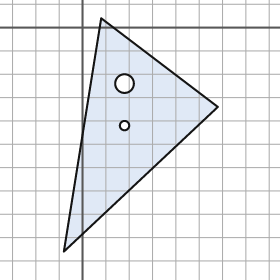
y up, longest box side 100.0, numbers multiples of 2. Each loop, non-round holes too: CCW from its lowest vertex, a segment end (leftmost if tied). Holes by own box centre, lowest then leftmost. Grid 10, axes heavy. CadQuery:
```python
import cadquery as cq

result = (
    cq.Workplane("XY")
    .moveTo(-8.0, -96.0)
    .lineTo(58.0, -34.0)
    .lineTo(8.0, 4.0)
    .close()
    .moveTo(18.0, -42.0)
    .circle(2.0)
    .moveTo(18.0, -24.0)
    .circle(4.0)
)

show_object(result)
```